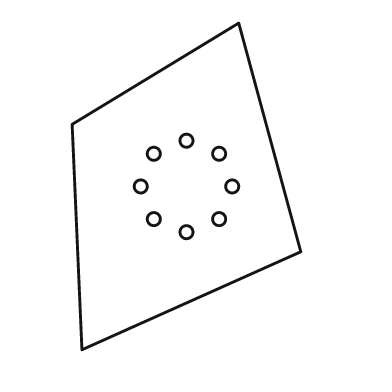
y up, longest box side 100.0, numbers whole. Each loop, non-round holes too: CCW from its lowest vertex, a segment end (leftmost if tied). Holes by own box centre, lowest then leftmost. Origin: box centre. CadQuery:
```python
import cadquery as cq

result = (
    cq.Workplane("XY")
    .moveTo(-32.0, -50.0)
    .lineTo(35.0, -20.0)
    .lineTo(16.0, 50.0)
    .lineTo(-35.0, 19.0)
    .close()
    .moveTo(0.0, -14.0)
    .circle(2.0)
    .moveTo(-10.0, -10.0)
    .circle(2.0)
    .moveTo(10.0, -10.0)
    .circle(2.0)
    .moveTo(-14.0, 0.0)
    .circle(2.0)
    .moveTo(14.0, 0.0)
    .circle(2.0)
    .moveTo(-10.0, 10.0)
    .circle(2.0)
    .moveTo(10.0, 10.0)
    .circle(2.0)
    .moveTo(0.0, 14.0)
    .circle(2.0)
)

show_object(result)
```